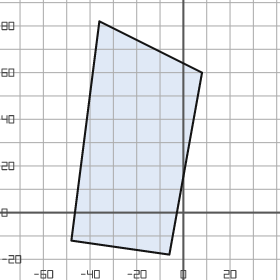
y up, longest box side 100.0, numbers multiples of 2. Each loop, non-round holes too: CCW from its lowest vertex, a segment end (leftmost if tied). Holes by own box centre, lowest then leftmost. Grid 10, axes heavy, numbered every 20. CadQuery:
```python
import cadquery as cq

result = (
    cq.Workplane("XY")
    .moveTo(-6.0, -18.0)
    .lineTo(8.0, 60.0)
    .lineTo(-36.0, 82.0)
    .lineTo(-48.0, -12.0)
    .close()
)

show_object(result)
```